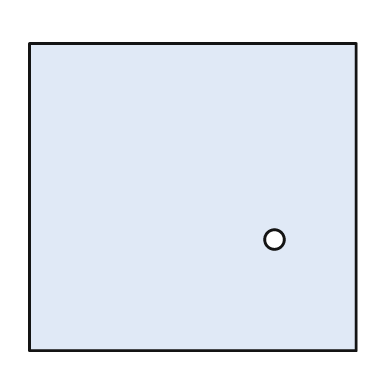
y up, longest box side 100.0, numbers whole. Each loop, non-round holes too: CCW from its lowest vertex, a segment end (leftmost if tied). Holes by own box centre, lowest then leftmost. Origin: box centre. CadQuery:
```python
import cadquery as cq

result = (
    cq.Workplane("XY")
    .moveTo(-50.0, -47.0)
    .lineTo(50.0, -47.0)
    .lineTo(50.0, 47.0)
    .lineTo(-50.0, 47.0)
    .close()
    .moveTo(25.0, -13.0)
    .circle(3.0)
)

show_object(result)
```